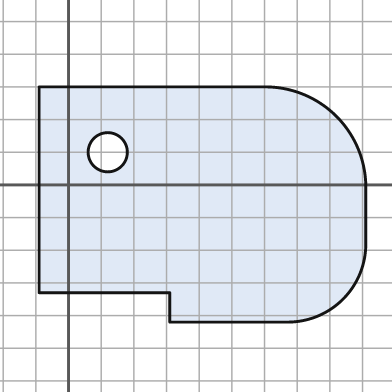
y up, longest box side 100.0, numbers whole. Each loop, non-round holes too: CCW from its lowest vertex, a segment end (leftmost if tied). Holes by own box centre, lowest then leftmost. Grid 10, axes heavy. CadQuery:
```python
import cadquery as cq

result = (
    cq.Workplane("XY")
    .moveTo(31.0, -42.0)
    .lineTo(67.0, -42.0)
    .threePointArc((84.0, -35.0), (91.0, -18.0))
    .lineTo(91.0, 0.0)
    .threePointArc((82.0, 21.0), (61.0, 30.0))
    .lineTo(-9.0, 30.0)
    .lineTo(-9.0, -33.0)
    .lineTo(31.0, -33.0)
    .close()
    .moveTo(12.0, 10.0)
    .circle(6.0)
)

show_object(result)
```